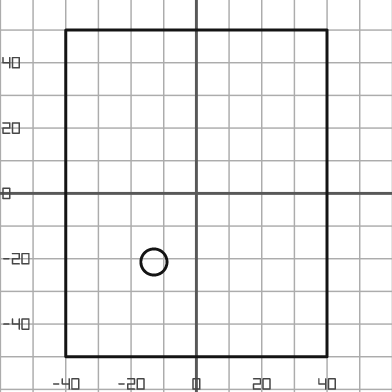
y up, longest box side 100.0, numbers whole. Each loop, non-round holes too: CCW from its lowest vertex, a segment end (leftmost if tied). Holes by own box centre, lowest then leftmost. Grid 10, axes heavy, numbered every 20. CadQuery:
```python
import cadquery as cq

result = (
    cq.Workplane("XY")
    .moveTo(-40.0, -50.0)
    .lineTo(40.0, -50.0)
    .lineTo(40.0, 50.0)
    .lineTo(-40.0, 50.0)
    .close()
    .moveTo(-13.0, -21.0)
    .circle(4.0)
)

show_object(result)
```